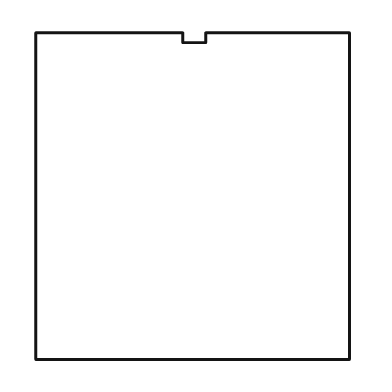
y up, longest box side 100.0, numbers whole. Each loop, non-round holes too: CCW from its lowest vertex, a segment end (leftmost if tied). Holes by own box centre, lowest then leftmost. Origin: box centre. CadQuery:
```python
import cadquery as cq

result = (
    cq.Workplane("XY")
    .moveTo(-48.0, -50.0)
    .lineTo(48.0, -50.0)
    .lineTo(48.0, 50.0)
    .lineTo(4.0, 50.0)
    .lineTo(4.0, 47.0)
    .lineTo(-3.0, 47.0)
    .lineTo(-3.0, 50.0)
    .lineTo(-48.0, 50.0)
    .close()
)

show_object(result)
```